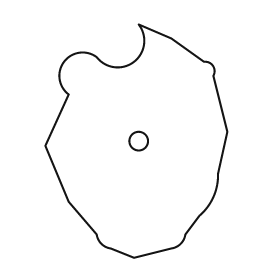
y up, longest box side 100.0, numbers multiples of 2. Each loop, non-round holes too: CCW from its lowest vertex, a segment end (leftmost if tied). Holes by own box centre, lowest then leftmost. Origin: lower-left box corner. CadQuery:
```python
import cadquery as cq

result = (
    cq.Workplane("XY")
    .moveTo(38.0, 0.0)
    .lineTo(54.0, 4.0)
    .threePointArc((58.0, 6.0), (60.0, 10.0))
    .lineTo(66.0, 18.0)
    .threePointArc((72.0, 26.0), (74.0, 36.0))
    .lineTo(78.0, 54.0)
    .lineTo(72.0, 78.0)
    .threePointArc((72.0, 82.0), (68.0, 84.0))
    .lineTo(54.0, 94.0)
    .lineTo(40.0, 100.0)
    .threePointArc((38.0, 84.0), (22.0, 86.0))
    .threePointArc((8.0, 84.0), (10.0, 70.0))
    .lineTo(0.0, 48.0)
    .lineTo(10.0, 24.0)
    .lineTo(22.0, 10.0)
    .threePointArc((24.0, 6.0), (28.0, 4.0))
    .close()
    .moveTo(40.0, 50.0)
    .circle(4.0)
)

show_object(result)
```